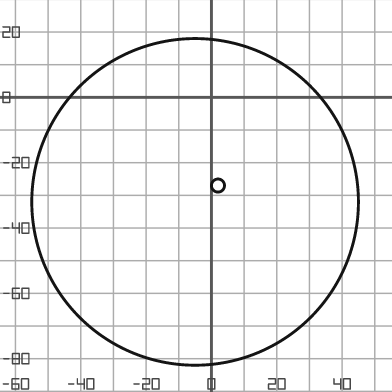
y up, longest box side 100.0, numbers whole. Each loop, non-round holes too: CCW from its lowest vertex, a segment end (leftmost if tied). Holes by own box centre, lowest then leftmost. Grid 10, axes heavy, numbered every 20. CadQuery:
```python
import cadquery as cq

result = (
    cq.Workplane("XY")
    .moveTo(-5.0, -32.0)
    .circle(50.0)
    .moveTo(2.0, -27.0)
    .circle(2.0)
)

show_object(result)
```